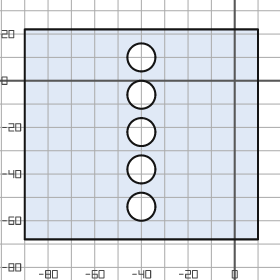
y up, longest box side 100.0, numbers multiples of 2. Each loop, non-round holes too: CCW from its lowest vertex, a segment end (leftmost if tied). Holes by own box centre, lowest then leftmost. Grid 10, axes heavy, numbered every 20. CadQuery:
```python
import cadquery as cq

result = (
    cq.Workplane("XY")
    .moveTo(-90.0, -68.0)
    .lineTo(10.0, -68.0)
    .lineTo(10.0, 22.0)
    .lineTo(-90.0, 22.0)
    .close()
    .moveTo(-40.0, -54.0)
    .circle(6.0)
    .moveTo(-40.0, -38.0)
    .circle(6.0)
    .moveTo(-40.0, -22.0)
    .circle(6.0)
    .moveTo(-40.0, -6.0)
    .circle(6.0)
    .moveTo(-40.0, 10.0)
    .circle(6.0)
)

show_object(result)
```